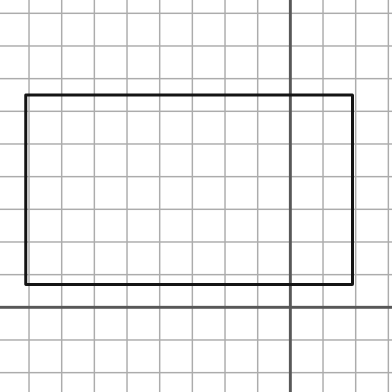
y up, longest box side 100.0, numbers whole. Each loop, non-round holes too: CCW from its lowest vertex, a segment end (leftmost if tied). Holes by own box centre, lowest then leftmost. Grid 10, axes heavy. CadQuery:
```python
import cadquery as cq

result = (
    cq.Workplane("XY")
    .moveTo(-81.0, 7.0)
    .lineTo(19.0, 7.0)
    .lineTo(19.0, 65.0)
    .lineTo(-81.0, 65.0)
    .close()
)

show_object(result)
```